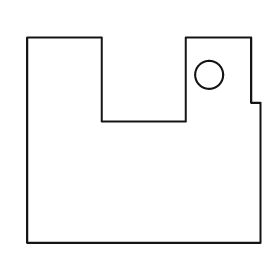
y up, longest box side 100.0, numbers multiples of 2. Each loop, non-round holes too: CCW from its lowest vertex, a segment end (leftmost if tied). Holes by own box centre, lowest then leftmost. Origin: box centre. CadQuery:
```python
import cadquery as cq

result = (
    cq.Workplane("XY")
    .moveTo(-50.0, -44.0)
    .lineTo(50.0, -44.0)
    .lineTo(50.0, 16.0)
    .lineTo(46.0, 16.0)
    .lineTo(46.0, 44.0)
    .lineTo(18.0, 44.0)
    .lineTo(18.0, 8.0)
    .lineTo(-18.0, 8.0)
    .lineTo(-18.0, 44.0)
    .lineTo(-50.0, 44.0)
    .close()
    .moveTo(28.0, 28.0)
    .circle(6.0)
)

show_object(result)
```